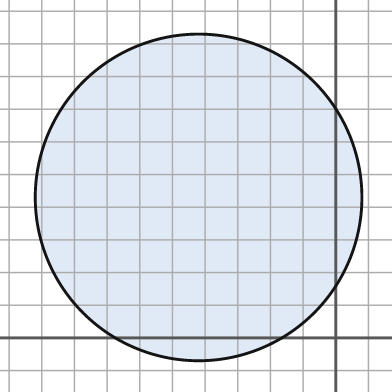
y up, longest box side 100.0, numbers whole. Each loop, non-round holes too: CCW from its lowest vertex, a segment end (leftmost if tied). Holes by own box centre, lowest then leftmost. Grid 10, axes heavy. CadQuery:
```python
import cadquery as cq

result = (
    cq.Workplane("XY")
    .moveTo(-42.0, 43.0)
    .circle(50.0)
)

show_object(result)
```